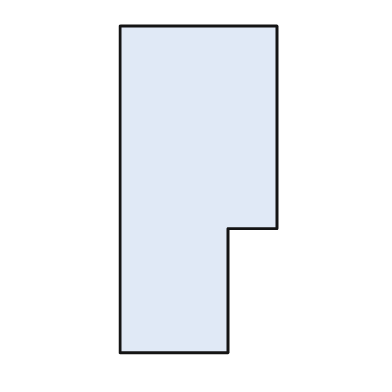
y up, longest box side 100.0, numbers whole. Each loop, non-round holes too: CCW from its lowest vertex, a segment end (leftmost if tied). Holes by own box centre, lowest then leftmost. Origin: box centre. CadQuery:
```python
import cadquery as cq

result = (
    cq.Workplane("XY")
    .moveTo(-24.0, -50.0)
    .lineTo(9.0, -50.0)
    .lineTo(9.0, -12.0)
    .lineTo(24.0, -12.0)
    .lineTo(24.0, 50.0)
    .lineTo(-24.0, 50.0)
    .close()
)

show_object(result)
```